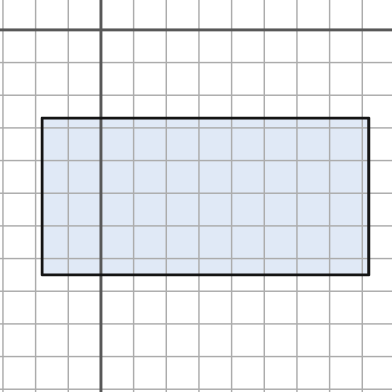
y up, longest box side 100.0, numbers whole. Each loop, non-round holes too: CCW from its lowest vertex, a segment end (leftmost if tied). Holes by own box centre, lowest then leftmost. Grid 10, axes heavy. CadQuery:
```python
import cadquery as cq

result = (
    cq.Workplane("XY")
    .moveTo(-18.0, -75.0)
    .lineTo(82.0, -75.0)
    .lineTo(82.0, -27.0)
    .lineTo(-18.0, -27.0)
    .close()
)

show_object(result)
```